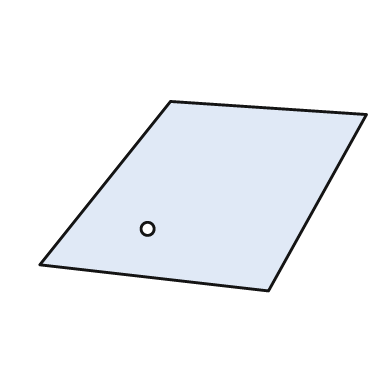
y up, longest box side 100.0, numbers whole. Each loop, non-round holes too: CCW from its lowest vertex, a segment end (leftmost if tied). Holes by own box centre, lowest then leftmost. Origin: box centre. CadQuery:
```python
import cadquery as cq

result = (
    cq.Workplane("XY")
    .moveTo(20.0, -29.0)
    .lineTo(50.0, 25.0)
    .lineTo(-10.0, 29.0)
    .lineTo(-50.0, -21.0)
    .close()
    .moveTo(-17.0, -10.0)
    .circle(2.0)
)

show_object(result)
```